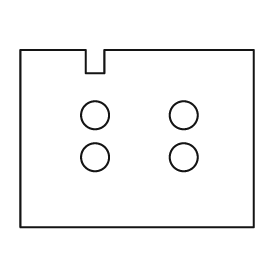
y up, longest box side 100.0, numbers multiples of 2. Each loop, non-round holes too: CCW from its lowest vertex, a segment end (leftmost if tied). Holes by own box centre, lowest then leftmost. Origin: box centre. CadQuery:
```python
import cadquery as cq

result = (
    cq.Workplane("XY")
    .moveTo(-50.0, -38.0)
    .lineTo(50.0, -38.0)
    .lineTo(50.0, 38.0)
    .lineTo(-14.0, 38.0)
    .lineTo(-14.0, 28.0)
    .lineTo(-22.0, 28.0)
    .lineTo(-22.0, 38.0)
    .lineTo(-50.0, 38.0)
    .close()
    .moveTo(-18.0, -8.0)
    .circle(6.0)
    .moveTo(20.0, -8.0)
    .circle(6.0)
    .moveTo(-18.0, 10.0)
    .circle(6.0)
    .moveTo(20.0, 10.0)
    .circle(6.0)
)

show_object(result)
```